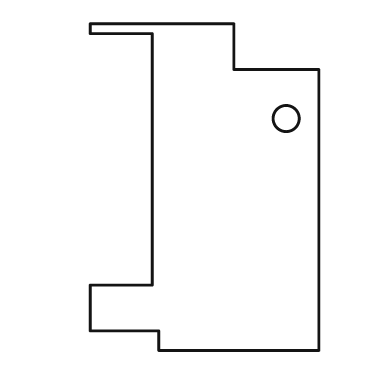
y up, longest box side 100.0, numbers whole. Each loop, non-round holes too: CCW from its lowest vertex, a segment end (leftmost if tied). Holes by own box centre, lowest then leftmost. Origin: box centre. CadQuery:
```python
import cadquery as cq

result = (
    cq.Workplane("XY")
    .moveTo(-14.0, -50.0)
    .lineTo(35.0, -50.0)
    .lineTo(35.0, 36.0)
    .lineTo(9.0, 36.0)
    .lineTo(9.0, 50.0)
    .lineTo(-35.0, 50.0)
    .lineTo(-35.0, 47.0)
    .lineTo(-16.0, 47.0)
    .lineTo(-16.0, -30.0)
    .lineTo(-35.0, -30.0)
    .lineTo(-35.0, -44.0)
    .lineTo(-14.0, -44.0)
    .close()
    .moveTo(25.0, 21.0)
    .circle(4.0)
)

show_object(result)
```